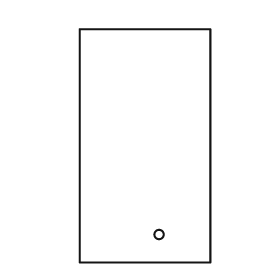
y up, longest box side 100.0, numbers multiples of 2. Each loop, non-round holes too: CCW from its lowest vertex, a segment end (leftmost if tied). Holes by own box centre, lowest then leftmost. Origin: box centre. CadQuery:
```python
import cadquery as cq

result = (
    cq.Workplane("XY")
    .moveTo(-28.0, -50.0)
    .lineTo(28.0, -50.0)
    .lineTo(28.0, 50.0)
    .lineTo(-28.0, 50.0)
    .close()
    .moveTo(6.0, -38.0)
    .circle(2.0)
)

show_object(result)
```